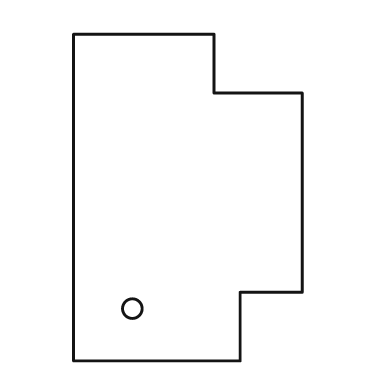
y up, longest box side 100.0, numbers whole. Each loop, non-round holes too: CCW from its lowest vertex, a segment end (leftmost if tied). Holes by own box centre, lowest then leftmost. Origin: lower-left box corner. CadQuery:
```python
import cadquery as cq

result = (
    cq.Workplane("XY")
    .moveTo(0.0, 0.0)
    .lineTo(51.0, 0.0)
    .lineTo(51.0, 21.0)
    .lineTo(70.0, 21.0)
    .lineTo(70.0, 82.0)
    .lineTo(43.0, 82.0)
    .lineTo(43.0, 100.0)
    .lineTo(0.0, 100.0)
    .close()
    .moveTo(18.0, 16.0)
    .circle(3.0)
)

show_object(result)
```